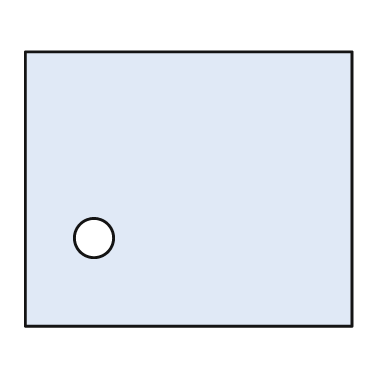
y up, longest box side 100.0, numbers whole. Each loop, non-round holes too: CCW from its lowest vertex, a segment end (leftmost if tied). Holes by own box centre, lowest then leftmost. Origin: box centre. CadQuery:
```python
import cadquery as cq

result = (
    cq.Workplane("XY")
    .moveTo(-50.0, -42.0)
    .lineTo(50.0, -42.0)
    .lineTo(50.0, 42.0)
    .lineTo(-50.0, 42.0)
    .close()
    .moveTo(-29.0, -15.0)
    .circle(6.0)
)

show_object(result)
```